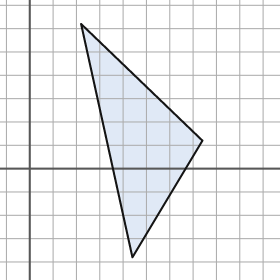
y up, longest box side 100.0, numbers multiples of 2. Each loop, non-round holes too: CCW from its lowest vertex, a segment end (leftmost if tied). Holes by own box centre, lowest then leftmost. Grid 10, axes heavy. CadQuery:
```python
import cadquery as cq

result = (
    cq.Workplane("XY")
    .moveTo(44.0, -38.0)
    .lineTo(74.0, 12.0)
    .lineTo(22.0, 62.0)
    .close()
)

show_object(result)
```